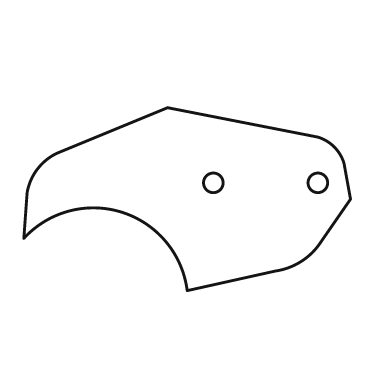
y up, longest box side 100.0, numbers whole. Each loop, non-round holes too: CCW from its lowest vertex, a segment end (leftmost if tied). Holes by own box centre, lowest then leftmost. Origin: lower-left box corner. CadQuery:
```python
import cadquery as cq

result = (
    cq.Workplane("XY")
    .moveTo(50.0, 0.0)
    .lineTo(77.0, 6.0)
    .threePointArc((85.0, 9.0), (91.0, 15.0))
    .lineTo(100.0, 28.0)
    .lineTo(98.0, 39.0)
    .threePointArc((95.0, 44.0), (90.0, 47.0))
    .lineTo(44.0, 56.0)
    .lineTo(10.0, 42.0)
    .threePointArc((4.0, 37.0), (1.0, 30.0))
    .lineTo(0.0, 16.0)
    .threePointArc((30.0, 24.0), (50.0, 0.0))
    .close()
    .moveTo(58.0, 33.0)
    .circle(3.0)
    .moveTo(90.0, 33.0)
    .circle(3.0)
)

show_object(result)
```